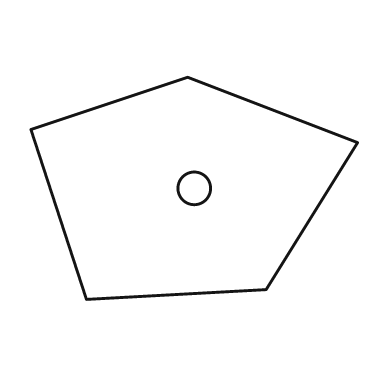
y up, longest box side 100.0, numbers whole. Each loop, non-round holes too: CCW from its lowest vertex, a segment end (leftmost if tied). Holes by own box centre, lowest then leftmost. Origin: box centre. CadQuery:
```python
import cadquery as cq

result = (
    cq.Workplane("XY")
    .moveTo(-33.0, -34.0)
    .lineTo(22.0, -31.0)
    .lineTo(50.0, 14.0)
    .lineTo(-2.0, 34.0)
    .lineTo(-50.0, 18.0)
    .close()
    .moveTo(0.0, 0.0)
    .circle(5.0)
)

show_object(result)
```